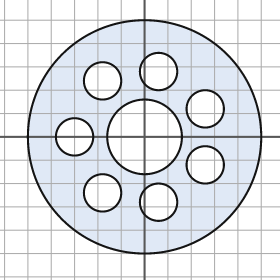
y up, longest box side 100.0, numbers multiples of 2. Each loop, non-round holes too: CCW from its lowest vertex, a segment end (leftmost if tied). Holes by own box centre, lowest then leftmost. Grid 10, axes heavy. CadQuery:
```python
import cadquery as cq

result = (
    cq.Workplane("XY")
    .moveTo(0.0, 0.0)
    .circle(50.0)
    .moveTo(6.0, -28.0)
    .circle(8.0)
    .moveTo(-18.0, -24.0)
    .circle(8.0)
    .moveTo(26.0, -12.0)
    .circle(8.0)
    .moveTo(-30.0, 0.0)
    .circle(8.0)
    .moveTo(0.0, 0.0)
    .circle(16.0)
    .moveTo(26.0, 12.0)
    .circle(8.0)
    .moveTo(-18.0, 24.0)
    .circle(8.0)
    .moveTo(6.0, 28.0)
    .circle(8.0)
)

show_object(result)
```